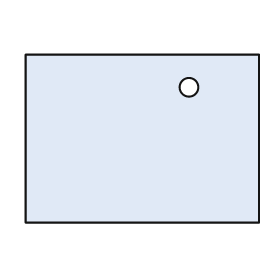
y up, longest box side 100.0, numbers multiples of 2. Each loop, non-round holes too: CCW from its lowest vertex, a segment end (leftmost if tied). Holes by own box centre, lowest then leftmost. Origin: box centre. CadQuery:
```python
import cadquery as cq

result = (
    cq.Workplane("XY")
    .moveTo(-50.0, -36.0)
    .lineTo(50.0, -36.0)
    .lineTo(50.0, 36.0)
    .lineTo(-50.0, 36.0)
    .close()
    .moveTo(20.0, 22.0)
    .circle(4.0)
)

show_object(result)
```